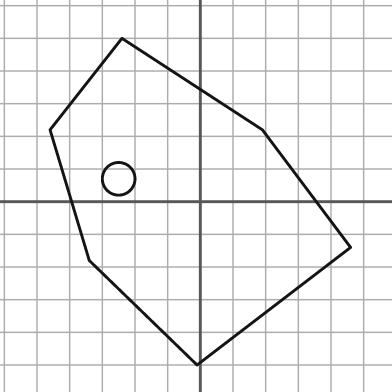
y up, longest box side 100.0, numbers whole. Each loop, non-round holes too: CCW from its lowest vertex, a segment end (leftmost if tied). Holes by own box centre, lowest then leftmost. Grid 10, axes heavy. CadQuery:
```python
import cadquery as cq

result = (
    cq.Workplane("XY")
    .moveTo(-1.0, -50.0)
    .lineTo(46.0, -14.0)
    .lineTo(19.0, 22.0)
    .lineTo(-24.0, 50.0)
    .lineTo(-46.0, 22.0)
    .lineTo(-34.0, -18.0)
    .close()
    .moveTo(-25.0, 7.0)
    .circle(5.0)
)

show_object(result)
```